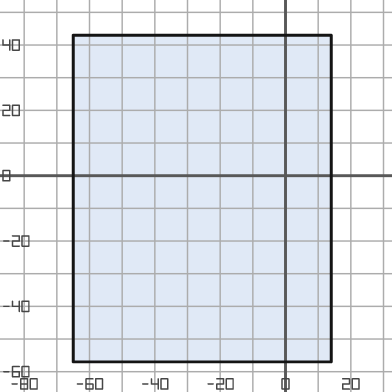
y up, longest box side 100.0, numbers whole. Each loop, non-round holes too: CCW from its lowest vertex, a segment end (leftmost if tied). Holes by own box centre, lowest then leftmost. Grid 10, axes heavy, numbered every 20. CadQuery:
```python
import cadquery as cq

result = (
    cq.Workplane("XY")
    .moveTo(-65.0, -57.0)
    .lineTo(14.0, -57.0)
    .lineTo(14.0, 43.0)
    .lineTo(-65.0, 43.0)
    .close()
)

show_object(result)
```